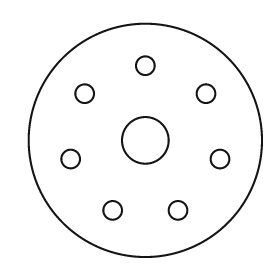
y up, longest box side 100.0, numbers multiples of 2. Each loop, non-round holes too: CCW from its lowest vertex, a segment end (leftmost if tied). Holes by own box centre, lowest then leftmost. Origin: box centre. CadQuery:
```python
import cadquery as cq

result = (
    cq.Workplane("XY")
    .moveTo(0.0, 0.0)
    .circle(50.0)
    .moveTo(-14.0, -30.0)
    .circle(4.0)
    .moveTo(14.0, -30.0)
    .circle(4.0)
    .moveTo(-32.0, -8.0)
    .circle(4.0)
    .moveTo(32.0, -8.0)
    .circle(4.0)
    .moveTo(0.0, 0.0)
    .circle(10.0)
    .moveTo(-26.0, 20.0)
    .circle(4.0)
    .moveTo(26.0, 20.0)
    .circle(4.0)
    .moveTo(0.0, 32.0)
    .circle(4.0)
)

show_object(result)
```